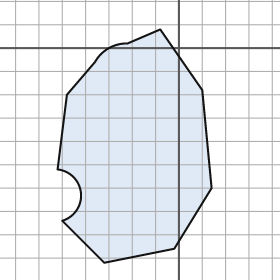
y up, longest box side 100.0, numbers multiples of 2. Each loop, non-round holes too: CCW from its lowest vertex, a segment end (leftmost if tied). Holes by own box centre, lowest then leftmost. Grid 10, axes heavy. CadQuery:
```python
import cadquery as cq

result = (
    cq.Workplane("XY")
    .moveTo(-32.0, -92.0)
    .lineTo(-2.0, -86.0)
    .lineTo(14.0, -60.0)
    .lineTo(10.0, -18.0)
    .lineTo(-8.0, 8.0)
    .lineTo(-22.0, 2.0)
    .threePointArc((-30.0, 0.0), (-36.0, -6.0))
    .lineTo(-48.0, -20.0)
    .lineTo(-52.0, -52.0)
    .threePointArc((-42.0, -62.0), (-50.0, -74.0))
    .close()
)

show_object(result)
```